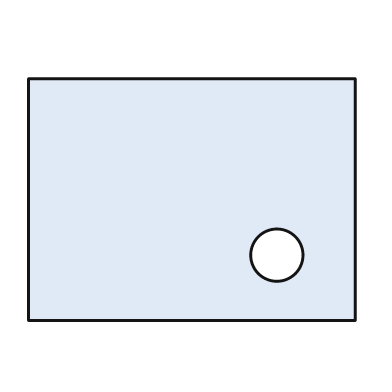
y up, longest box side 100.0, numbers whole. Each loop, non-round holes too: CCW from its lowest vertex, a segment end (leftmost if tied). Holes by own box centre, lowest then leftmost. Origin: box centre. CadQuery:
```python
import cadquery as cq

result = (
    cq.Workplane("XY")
    .moveTo(-50.0, -37.0)
    .lineTo(50.0, -37.0)
    .lineTo(50.0, 37.0)
    .lineTo(-50.0, 37.0)
    .close()
    .moveTo(26.0, -17.0)
    .circle(8.0)
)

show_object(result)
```